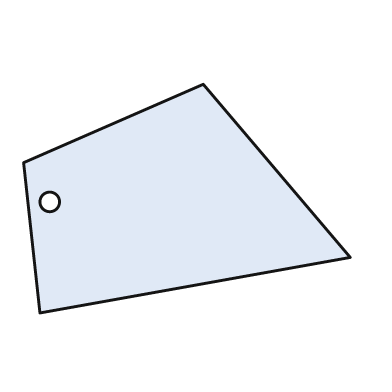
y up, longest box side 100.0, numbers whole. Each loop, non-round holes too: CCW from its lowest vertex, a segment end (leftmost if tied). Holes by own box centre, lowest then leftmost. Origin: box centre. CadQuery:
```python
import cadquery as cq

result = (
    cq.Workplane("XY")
    .moveTo(-45.0, -35.0)
    .lineTo(50.0, -18.0)
    .lineTo(5.0, 35.0)
    .lineTo(-50.0, 11.0)
    .close()
    .moveTo(-42.0, -1.0)
    .circle(3.0)
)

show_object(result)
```